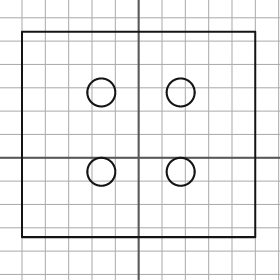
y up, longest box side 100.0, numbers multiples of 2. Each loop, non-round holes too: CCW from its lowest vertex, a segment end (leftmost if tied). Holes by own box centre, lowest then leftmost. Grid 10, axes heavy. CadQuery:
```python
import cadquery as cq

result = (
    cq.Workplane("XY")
    .moveTo(-50.0, -34.0)
    .lineTo(50.0, -34.0)
    .lineTo(50.0, 54.0)
    .lineTo(-50.0, 54.0)
    .close()
    .moveTo(-16.0, -6.0)
    .circle(6.0)
    .moveTo(18.0, -6.0)
    .circle(6.0)
    .moveTo(-16.0, 28.0)
    .circle(6.0)
    .moveTo(18.0, 28.0)
    .circle(6.0)
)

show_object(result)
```